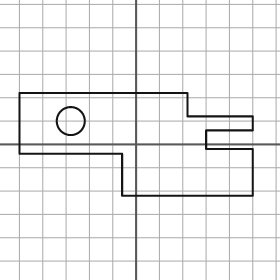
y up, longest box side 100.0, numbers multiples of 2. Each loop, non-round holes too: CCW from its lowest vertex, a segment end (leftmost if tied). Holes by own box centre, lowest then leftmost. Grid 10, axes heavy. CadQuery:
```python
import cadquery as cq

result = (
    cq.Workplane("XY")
    .moveTo(-6.0, -22.0)
    .lineTo(50.0, -22.0)
    .lineTo(50.0, -2.0)
    .lineTo(30.0, -2.0)
    .lineTo(30.0, 6.0)
    .lineTo(50.0, 6.0)
    .lineTo(50.0, 12.0)
    .lineTo(22.0, 12.0)
    .lineTo(22.0, 22.0)
    .lineTo(-50.0, 22.0)
    .lineTo(-50.0, -4.0)
    .lineTo(-6.0, -4.0)
    .close()
    .moveTo(-28.0, 10.0)
    .circle(6.0)
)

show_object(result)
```